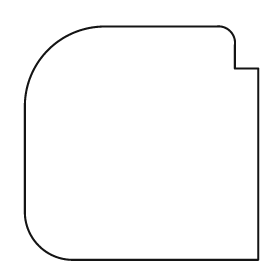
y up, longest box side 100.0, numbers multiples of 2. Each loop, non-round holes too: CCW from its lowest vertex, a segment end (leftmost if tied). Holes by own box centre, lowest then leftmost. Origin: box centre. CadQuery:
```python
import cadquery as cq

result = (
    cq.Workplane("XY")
    .moveTo(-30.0, -50.0)
    .lineTo(50.0, -50.0)
    .lineTo(50.0, 32.0)
    .lineTo(40.0, 32.0)
    .lineTo(40.0, 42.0)
    .threePointArc((38.0, 48.0), (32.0, 50.0))
    .lineTo(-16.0, 50.0)
    .threePointArc((-40.0, 40.0), (-50.0, 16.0))
    .lineTo(-50.0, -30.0)
    .threePointArc((-44.0, -44.0), (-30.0, -50.0))
    .close()
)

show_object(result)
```